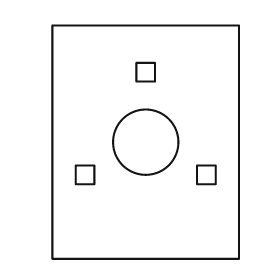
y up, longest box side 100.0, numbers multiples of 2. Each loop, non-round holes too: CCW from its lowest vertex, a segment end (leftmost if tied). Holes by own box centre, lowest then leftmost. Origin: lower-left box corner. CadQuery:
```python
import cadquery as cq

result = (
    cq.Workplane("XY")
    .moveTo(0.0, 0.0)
    .lineTo(80.0, 0.0)
    .lineTo(80.0, 100.0)
    .lineTo(0.0, 100.0)
    .close()
    .moveTo(10.0, 32.0)
    .lineTo(18.0, 32.0)
    .lineTo(18.0, 40.0)
    .lineTo(10.0, 40.0)
    .close()
    .moveTo(62.0, 32.0)
    .lineTo(70.0, 32.0)
    .lineTo(70.0, 40.0)
    .lineTo(62.0, 40.0)
    .close()
    .moveTo(40.0, 50.0)
    .circle(14.0)
    .moveTo(36.0, 76.0)
    .lineTo(44.0, 76.0)
    .lineTo(44.0, 84.0)
    .lineTo(36.0, 84.0)
    .close()
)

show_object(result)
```